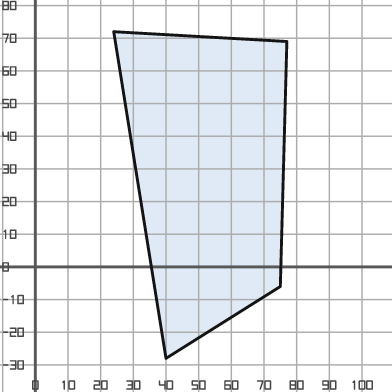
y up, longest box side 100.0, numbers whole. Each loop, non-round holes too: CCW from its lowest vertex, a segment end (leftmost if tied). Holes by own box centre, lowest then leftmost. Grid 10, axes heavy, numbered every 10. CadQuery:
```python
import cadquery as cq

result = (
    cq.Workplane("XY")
    .moveTo(40.0, -28.0)
    .lineTo(75.0, -6.0)
    .lineTo(77.0, 69.0)
    .lineTo(24.0, 72.0)
    .close()
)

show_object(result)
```